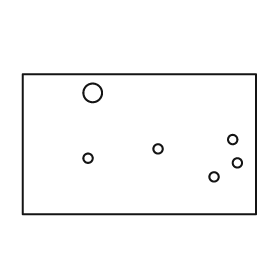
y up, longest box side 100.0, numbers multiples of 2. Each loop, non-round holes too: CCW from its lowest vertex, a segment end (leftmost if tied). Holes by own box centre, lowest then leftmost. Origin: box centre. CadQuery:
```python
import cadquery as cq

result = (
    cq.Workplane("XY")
    .moveTo(-50.0, -30.0)
    .lineTo(50.0, -30.0)
    .lineTo(50.0, 30.0)
    .lineTo(-50.0, 30.0)
    .close()
    .moveTo(32.0, -14.0)
    .circle(2.0)
    .moveTo(42.0, -8.0)
    .circle(2.0)
    .moveTo(-22.0, -6.0)
    .circle(2.0)
    .moveTo(8.0, -2.0)
    .circle(2.0)
    .moveTo(40.0, 2.0)
    .circle(2.0)
    .moveTo(-20.0, 22.0)
    .circle(4.0)
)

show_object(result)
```